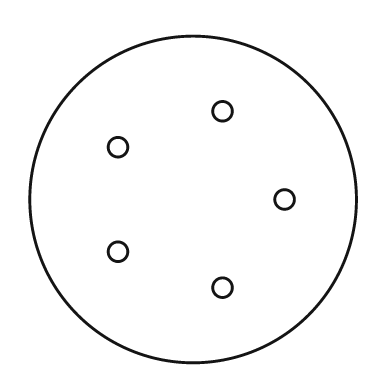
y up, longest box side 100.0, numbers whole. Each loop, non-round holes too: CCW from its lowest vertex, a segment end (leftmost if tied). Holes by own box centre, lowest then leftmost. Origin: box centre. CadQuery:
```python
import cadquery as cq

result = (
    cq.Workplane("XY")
    .moveTo(0.0, 0.0)
    .circle(50.0)
    .moveTo(9.0, -27.0)
    .circle(3.0)
    .moveTo(-23.0, -16.0)
    .circle(3.0)
    .moveTo(28.0, 0.0)
    .circle(3.0)
    .moveTo(-23.0, 16.0)
    .circle(3.0)
    .moveTo(9.0, 27.0)
    .circle(3.0)
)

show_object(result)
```